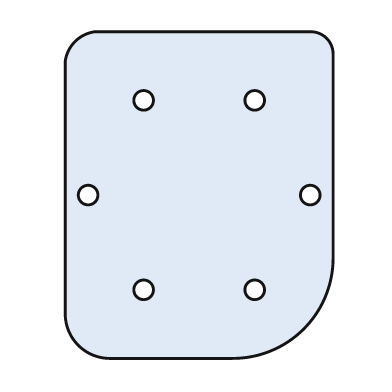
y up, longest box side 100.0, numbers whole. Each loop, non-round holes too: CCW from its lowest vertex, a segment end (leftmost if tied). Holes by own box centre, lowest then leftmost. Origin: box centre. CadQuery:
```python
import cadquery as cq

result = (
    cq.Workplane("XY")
    .moveTo(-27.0, -50.0)
    .lineTo(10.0, -50.0)
    .threePointArc((32.0, -41.0), (41.0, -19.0))
    .lineTo(41.0, 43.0)
    .threePointArc((39.0, 48.0), (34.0, 50.0))
    .lineTo(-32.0, 50.0)
    .threePointArc((-38.0, 47.0), (-41.0, 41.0))
    .lineTo(-41.0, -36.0)
    .threePointArc((-37.0, -46.0), (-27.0, -50.0))
    .close()
    .moveTo(-17.0, -29.0)
    .circle(3.0)
    .moveTo(17.0, -29.0)
    .circle(3.0)
    .moveTo(-34.0, 0.0)
    .circle(3.0)
    .moveTo(34.0, 0.0)
    .circle(3.0)
    .moveTo(-17.0, 29.0)
    .circle(3.0)
    .moveTo(17.0, 29.0)
    .circle(3.0)
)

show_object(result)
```